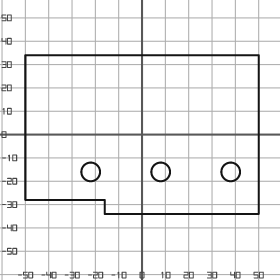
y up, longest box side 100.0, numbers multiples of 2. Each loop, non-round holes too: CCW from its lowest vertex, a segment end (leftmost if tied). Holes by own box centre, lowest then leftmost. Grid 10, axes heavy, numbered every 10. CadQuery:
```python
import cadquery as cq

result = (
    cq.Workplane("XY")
    .moveTo(-16.0, -34.0)
    .lineTo(50.0, -34.0)
    .lineTo(50.0, 34.0)
    .lineTo(-50.0, 34.0)
    .lineTo(-50.0, -28.0)
    .lineTo(-16.0, -28.0)
    .close()
    .moveTo(-22.0, -16.0)
    .circle(4.0)
    .moveTo(8.0, -16.0)
    .circle(4.0)
    .moveTo(38.0, -16.0)
    .circle(4.0)
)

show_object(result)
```